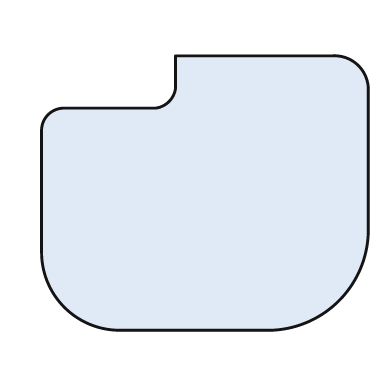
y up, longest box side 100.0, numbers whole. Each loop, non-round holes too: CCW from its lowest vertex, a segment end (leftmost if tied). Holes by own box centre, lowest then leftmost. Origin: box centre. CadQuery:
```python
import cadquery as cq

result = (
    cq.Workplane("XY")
    .moveTo(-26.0, -42.0)
    .lineTo(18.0, -42.0)
    .threePointArc((41.0, -33.0), (50.0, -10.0))
    .lineTo(50.0, 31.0)
    .threePointArc((47.0, 39.0), (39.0, 42.0))
    .lineTo(-9.0, 42.0)
    .lineTo(-9.0, 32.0)
    .threePointArc((-11.0, 28.0), (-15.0, 26.0))
    .lineTo(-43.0, 26.0)
    .threePointArc((-48.0, 24.0), (-50.0, 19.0))
    .lineTo(-50.0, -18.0)
    .threePointArc((-43.0, -35.0), (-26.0, -42.0))
    .close()
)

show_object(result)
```